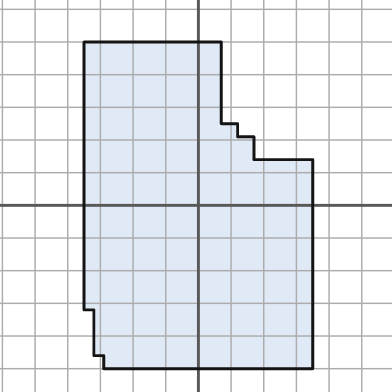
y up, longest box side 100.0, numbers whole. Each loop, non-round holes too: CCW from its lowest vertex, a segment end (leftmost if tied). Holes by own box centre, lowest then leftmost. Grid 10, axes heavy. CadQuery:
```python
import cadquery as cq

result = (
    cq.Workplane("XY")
    .moveTo(-29.0, -50.0)
    .lineTo(35.0, -50.0)
    .lineTo(35.0, 14.0)
    .lineTo(17.0, 14.0)
    .lineTo(17.0, 21.0)
    .lineTo(12.0, 21.0)
    .lineTo(12.0, 25.0)
    .lineTo(7.0, 25.0)
    .lineTo(7.0, 50.0)
    .lineTo(-35.0, 50.0)
    .lineTo(-35.0, -32.0)
    .lineTo(-32.0, -32.0)
    .lineTo(-32.0, -46.0)
    .lineTo(-29.0, -46.0)
    .close()
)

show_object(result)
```